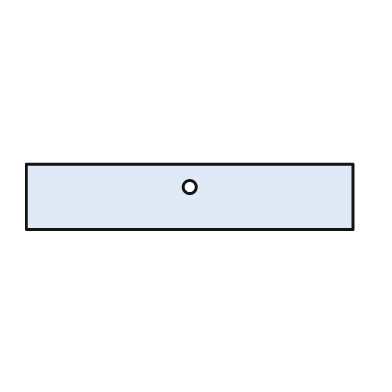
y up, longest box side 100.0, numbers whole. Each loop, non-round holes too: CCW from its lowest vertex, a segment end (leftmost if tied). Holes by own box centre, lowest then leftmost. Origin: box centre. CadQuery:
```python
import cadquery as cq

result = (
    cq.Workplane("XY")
    .moveTo(-50.0, -10.0)
    .lineTo(50.0, -10.0)
    .lineTo(50.0, 10.0)
    .lineTo(-50.0, 10.0)
    .close()
    .moveTo(0.0, 3.0)
    .circle(2.0)
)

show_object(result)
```